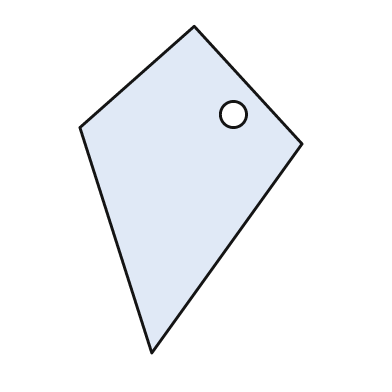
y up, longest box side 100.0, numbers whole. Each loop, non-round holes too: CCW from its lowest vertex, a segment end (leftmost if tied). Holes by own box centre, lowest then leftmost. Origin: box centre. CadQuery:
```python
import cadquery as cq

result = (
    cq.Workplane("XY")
    .moveTo(-12.0, -50.0)
    .lineTo(34.0, 14.0)
    .lineTo(1.0, 50.0)
    .lineTo(-34.0, 19.0)
    .close()
    .moveTo(13.0, 23.0)
    .circle(4.0)
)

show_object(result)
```